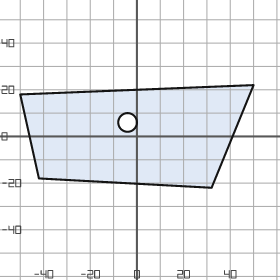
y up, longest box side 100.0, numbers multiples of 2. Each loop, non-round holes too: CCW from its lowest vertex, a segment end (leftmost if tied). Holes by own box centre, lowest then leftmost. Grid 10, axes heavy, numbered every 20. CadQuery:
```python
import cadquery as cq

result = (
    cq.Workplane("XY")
    .moveTo(32.0, -22.0)
    .lineTo(50.0, 22.0)
    .lineTo(-50.0, 18.0)
    .lineTo(-42.0, -18.0)
    .close()
    .moveTo(-4.0, 6.0)
    .circle(4.0)
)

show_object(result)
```